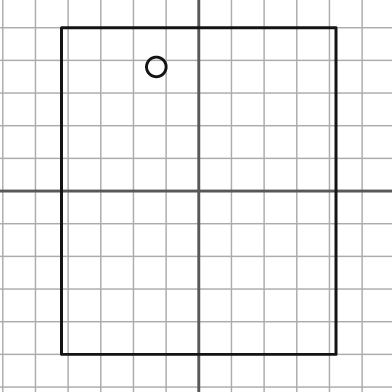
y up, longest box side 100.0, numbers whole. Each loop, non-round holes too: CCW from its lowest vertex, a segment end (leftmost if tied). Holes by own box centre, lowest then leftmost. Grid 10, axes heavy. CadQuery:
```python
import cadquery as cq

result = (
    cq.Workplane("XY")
    .moveTo(-42.0, -50.0)
    .lineTo(42.0, -50.0)
    .lineTo(42.0, 50.0)
    .lineTo(-42.0, 50.0)
    .close()
    .moveTo(-13.0, 38.0)
    .circle(3.0)
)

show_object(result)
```